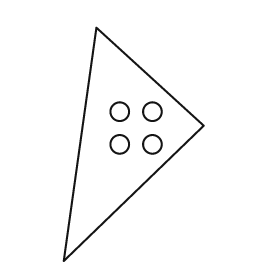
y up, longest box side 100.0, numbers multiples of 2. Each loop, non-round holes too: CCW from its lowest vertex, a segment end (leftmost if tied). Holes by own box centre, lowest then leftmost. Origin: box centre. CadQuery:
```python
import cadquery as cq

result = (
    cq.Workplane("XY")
    .moveTo(-30.0, -50.0)
    .lineTo(30.0, 8.0)
    .lineTo(-16.0, 50.0)
    .close()
    .moveTo(-6.0, 0.0)
    .circle(4.0)
    .moveTo(8.0, 0.0)
    .circle(4.0)
    .moveTo(-6.0, 14.0)
    .circle(4.0)
    .moveTo(8.0, 14.0)
    .circle(4.0)
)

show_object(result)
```